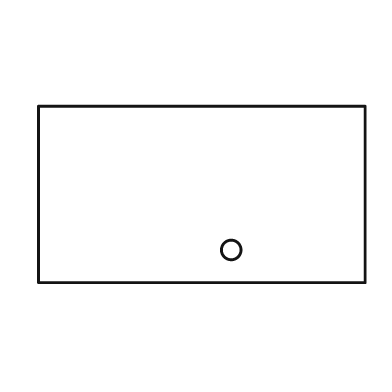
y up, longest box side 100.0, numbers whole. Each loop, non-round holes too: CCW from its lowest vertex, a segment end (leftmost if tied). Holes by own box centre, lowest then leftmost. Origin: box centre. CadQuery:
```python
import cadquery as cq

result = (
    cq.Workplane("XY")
    .moveTo(-50.0, -27.0)
    .lineTo(50.0, -27.0)
    .lineTo(50.0, 27.0)
    .lineTo(-50.0, 27.0)
    .close()
    .moveTo(9.0, -17.0)
    .circle(3.0)
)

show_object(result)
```